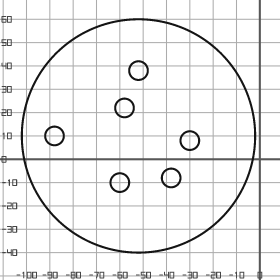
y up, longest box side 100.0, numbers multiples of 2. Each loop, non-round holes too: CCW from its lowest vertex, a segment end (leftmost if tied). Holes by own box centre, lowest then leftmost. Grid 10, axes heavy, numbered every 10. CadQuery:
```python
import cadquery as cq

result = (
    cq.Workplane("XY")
    .moveTo(-52.0, 10.0)
    .circle(50.0)
    .moveTo(-60.0, -10.0)
    .circle(4.0)
    .moveTo(-38.0, -8.0)
    .circle(4.0)
    .moveTo(-30.0, 8.0)
    .circle(4.0)
    .moveTo(-88.0, 10.0)
    .circle(4.0)
    .moveTo(-58.0, 22.0)
    .circle(4.0)
    .moveTo(-52.0, 38.0)
    .circle(4.0)
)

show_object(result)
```